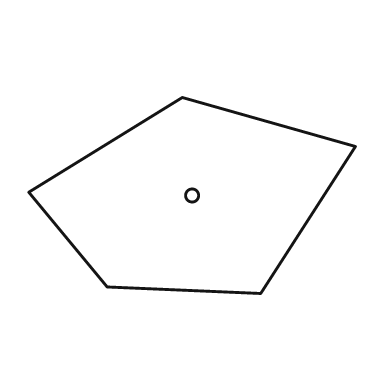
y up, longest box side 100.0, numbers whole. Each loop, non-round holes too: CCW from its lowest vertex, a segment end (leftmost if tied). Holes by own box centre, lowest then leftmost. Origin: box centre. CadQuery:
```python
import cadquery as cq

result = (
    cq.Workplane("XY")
    .moveTo(21.0, -30.0)
    .lineTo(50.0, 15.0)
    .lineTo(-3.0, 30.0)
    .lineTo(-50.0, 1.0)
    .lineTo(-26.0, -28.0)
    .close()
    .moveTo(0.0, 0.0)
    .circle(2.0)
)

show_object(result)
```